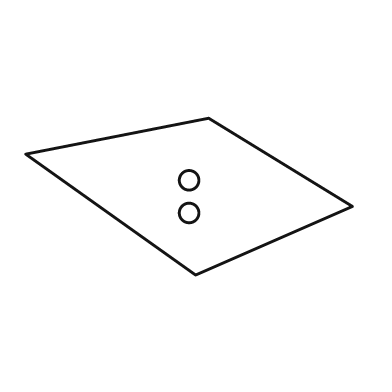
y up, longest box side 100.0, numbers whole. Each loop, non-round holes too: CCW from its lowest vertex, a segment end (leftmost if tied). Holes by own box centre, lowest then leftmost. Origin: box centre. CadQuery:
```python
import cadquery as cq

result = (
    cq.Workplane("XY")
    .moveTo(2.0, -24.0)
    .lineTo(50.0, -3.0)
    .lineTo(6.0, 24.0)
    .lineTo(-50.0, 13.0)
    .close()
    .moveTo(0.0, -5.0)
    .circle(3.0)
    .moveTo(0.0, 5.0)
    .circle(3.0)
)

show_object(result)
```